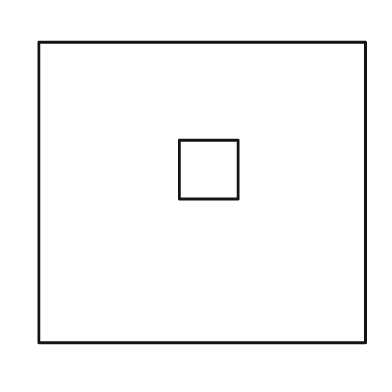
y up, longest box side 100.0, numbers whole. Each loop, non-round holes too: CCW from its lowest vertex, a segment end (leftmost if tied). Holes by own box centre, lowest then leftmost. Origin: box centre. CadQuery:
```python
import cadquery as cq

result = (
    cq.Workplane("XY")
    .moveTo(-50.0, -46.0)
    .lineTo(50.0, -46.0)
    .lineTo(50.0, 46.0)
    .lineTo(-50.0, 46.0)
    .close()
    .moveTo(-7.0, -2.0)
    .lineTo(11.0, -2.0)
    .lineTo(11.0, 16.0)
    .lineTo(-7.0, 16.0)
    .close()
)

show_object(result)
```